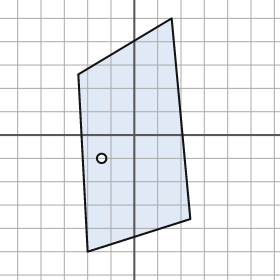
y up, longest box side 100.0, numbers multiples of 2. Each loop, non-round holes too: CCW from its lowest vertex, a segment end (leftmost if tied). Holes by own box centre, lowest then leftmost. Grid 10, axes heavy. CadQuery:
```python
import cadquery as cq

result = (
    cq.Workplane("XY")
    .moveTo(-20.0, -50.0)
    .lineTo(24.0, -36.0)
    .lineTo(16.0, 50.0)
    .lineTo(-24.0, 26.0)
    .close()
    .moveTo(-14.0, -10.0)
    .circle(2.0)
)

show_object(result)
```